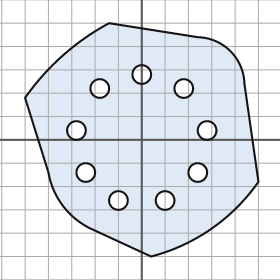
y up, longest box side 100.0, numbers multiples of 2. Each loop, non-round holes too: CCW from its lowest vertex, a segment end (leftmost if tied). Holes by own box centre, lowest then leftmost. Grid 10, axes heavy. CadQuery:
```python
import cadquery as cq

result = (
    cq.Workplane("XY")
    .moveTo(4.0, -50.0)
    .threePointArc((30.0, -38.0), (50.0, -18.0))
    .lineTo(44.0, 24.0)
    .threePointArc((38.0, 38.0), (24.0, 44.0))
    .lineTo(-14.0, 50.0)
    .threePointArc((-34.0, 36.0), (-50.0, 18.0))
    .lineTo(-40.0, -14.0)
    .threePointArc((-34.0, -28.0), (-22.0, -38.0))
    .close()
    .moveTo(-10.0, -26.0)
    .circle(4.0)
    .moveTo(10.0, -26.0)
    .circle(4.0)
    .moveTo(-24.0, -14.0)
    .circle(4.0)
    .moveTo(24.0, -14.0)
    .circle(4.0)
    .moveTo(-28.0, 4.0)
    .circle(4.0)
    .moveTo(28.0, 4.0)
    .circle(4.0)
    .moveTo(-18.0, 22.0)
    .circle(4.0)
    .moveTo(18.0, 22.0)
    .circle(4.0)
    .moveTo(0.0, 28.0)
    .circle(4.0)
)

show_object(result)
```